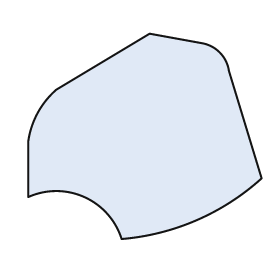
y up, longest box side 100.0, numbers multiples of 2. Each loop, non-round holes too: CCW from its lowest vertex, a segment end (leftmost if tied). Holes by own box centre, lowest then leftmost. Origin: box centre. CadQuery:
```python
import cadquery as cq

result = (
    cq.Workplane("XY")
    .moveTo(-10.0, -44.0)
    .threePointArc((22.0, -36.0), (50.0, -18.0))
    .lineTo(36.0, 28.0)
    .threePointArc((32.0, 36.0), (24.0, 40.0))
    .lineTo(2.0, 44.0)
    .lineTo(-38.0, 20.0)
    .threePointArc((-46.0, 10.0), (-50.0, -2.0))
    .lineTo(-50.0, -26.0)
    .threePointArc((-26.0, -26.0), (-10.0, -44.0))
    .close()
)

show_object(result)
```